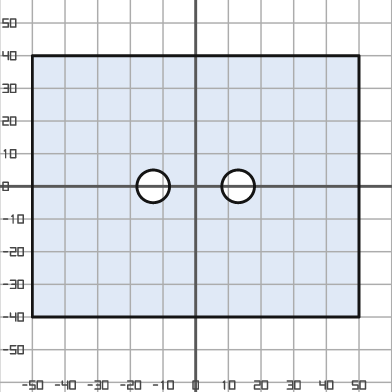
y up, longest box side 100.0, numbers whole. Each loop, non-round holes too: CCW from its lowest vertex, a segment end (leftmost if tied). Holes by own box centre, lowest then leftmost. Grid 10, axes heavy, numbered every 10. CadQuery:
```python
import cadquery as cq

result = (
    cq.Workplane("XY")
    .moveTo(-50.0, -40.0)
    .lineTo(50.0, -40.0)
    .lineTo(50.0, 40.0)
    .lineTo(-50.0, 40.0)
    .close()
    .moveTo(-13.0, 0.0)
    .circle(5.0)
    .moveTo(13.0, 0.0)
    .circle(5.0)
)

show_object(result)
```